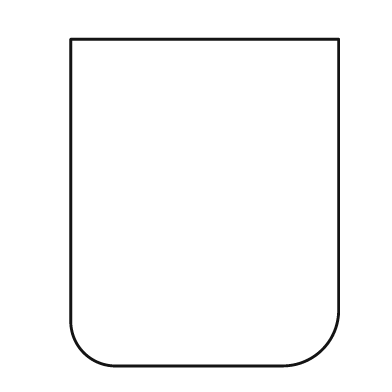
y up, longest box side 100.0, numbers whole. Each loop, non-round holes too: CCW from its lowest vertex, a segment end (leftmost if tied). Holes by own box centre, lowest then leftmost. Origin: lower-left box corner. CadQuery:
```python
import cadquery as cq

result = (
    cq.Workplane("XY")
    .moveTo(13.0, 0.0)
    .lineTo(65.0, 0.0)
    .threePointArc((77.0, 5.0), (82.0, 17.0))
    .lineTo(82.0, 100.0)
    .lineTo(0.0, 100.0)
    .lineTo(0.0, 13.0)
    .threePointArc((4.0, 4.0), (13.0, 0.0))
    .close()
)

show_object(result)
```